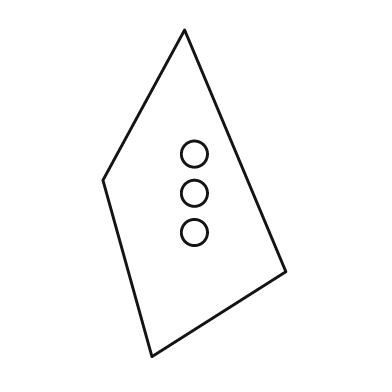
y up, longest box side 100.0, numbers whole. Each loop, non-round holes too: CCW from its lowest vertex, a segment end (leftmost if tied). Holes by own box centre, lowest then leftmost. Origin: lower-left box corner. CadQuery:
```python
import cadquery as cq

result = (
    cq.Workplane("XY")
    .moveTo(15.0, 0.0)
    .lineTo(56.0, 26.0)
    .lineTo(25.0, 100.0)
    .lineTo(0.0, 54.0)
    .close()
    .moveTo(28.0, 38.0)
    .circle(4.0)
    .moveTo(28.0, 50.0)
    .circle(4.0)
    .moveTo(28.0, 62.0)
    .circle(4.0)
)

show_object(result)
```